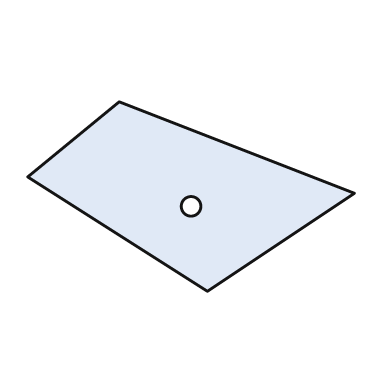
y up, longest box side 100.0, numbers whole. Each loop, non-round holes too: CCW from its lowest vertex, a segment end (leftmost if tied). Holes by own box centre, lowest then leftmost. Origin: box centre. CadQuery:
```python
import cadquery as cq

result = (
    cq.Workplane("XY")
    .moveTo(5.0, -29.0)
    .lineTo(50.0, 1.0)
    .lineTo(-22.0, 29.0)
    .lineTo(-50.0, 6.0)
    .close()
    .moveTo(0.0, -3.0)
    .circle(3.0)
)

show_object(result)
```